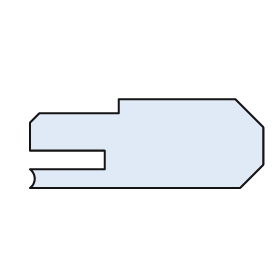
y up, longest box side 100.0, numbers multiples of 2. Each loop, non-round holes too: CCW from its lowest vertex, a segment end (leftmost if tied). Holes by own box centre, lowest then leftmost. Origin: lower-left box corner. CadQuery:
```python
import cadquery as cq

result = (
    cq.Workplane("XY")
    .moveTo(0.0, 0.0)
    .lineTo(90.0, 0.0)
    .lineTo(100.0, 10.0)
    .lineTo(100.0, 26.0)
    .lineTo(88.0, 38.0)
    .lineTo(38.0, 38.0)
    .lineTo(38.0, 32.0)
    .lineTo(4.0, 32.0)
    .lineTo(0.0, 28.0)
    .lineTo(0.0, 16.0)
    .lineTo(32.0, 16.0)
    .lineTo(32.0, 8.0)
    .lineTo(0.0, 8.0)
    .threePointArc((2.0, 4.0), (0.0, 0.0))
    .close()
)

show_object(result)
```